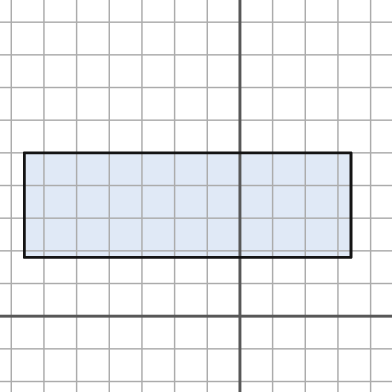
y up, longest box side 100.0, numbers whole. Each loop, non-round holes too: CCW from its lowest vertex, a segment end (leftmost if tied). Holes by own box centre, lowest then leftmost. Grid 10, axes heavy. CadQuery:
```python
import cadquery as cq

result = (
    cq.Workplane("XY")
    .moveTo(-66.0, 18.0)
    .lineTo(34.0, 18.0)
    .lineTo(34.0, 50.0)
    .lineTo(-66.0, 50.0)
    .close()
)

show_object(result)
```